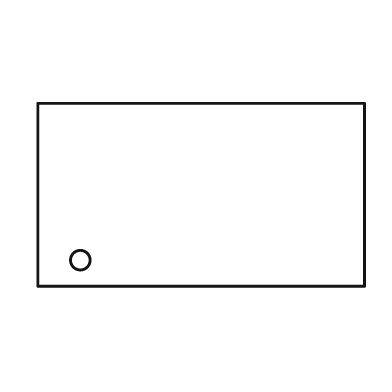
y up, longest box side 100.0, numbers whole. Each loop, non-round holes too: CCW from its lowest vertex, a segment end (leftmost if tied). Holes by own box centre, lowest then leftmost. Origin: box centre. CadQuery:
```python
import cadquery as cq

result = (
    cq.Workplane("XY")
    .moveTo(-50.0, -28.0)
    .lineTo(50.0, -28.0)
    .lineTo(50.0, 28.0)
    .lineTo(-50.0, 28.0)
    .close()
    .moveTo(-37.0, -20.0)
    .circle(3.0)
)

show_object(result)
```